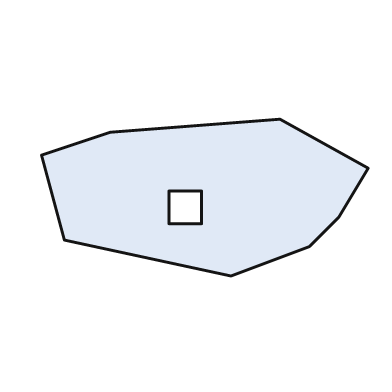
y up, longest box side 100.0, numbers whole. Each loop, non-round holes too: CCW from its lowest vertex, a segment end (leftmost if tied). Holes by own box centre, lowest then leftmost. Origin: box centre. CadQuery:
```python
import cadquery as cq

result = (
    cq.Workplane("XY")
    .moveTo(8.0, -24.0)
    .lineTo(32.0, -15.0)
    .lineTo(41.0, -6.0)
    .lineTo(50.0, 9.0)
    .lineTo(23.0, 24.0)
    .lineTo(-29.0, 20.0)
    .lineTo(-50.0, 13.0)
    .lineTo(-43.0, -13.0)
    .close()
    .moveTo(-11.0, -8.0)
    .lineTo(-1.0, -8.0)
    .lineTo(-1.0, 2.0)
    .lineTo(-11.0, 2.0)
    .close()
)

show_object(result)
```